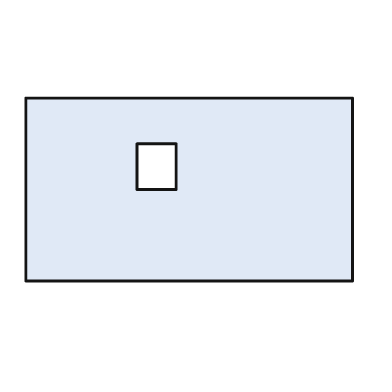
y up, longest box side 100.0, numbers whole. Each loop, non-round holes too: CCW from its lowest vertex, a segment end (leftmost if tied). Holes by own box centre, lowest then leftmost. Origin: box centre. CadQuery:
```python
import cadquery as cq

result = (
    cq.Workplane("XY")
    .moveTo(-50.0, -28.0)
    .lineTo(50.0, -28.0)
    .lineTo(50.0, 28.0)
    .lineTo(-50.0, 28.0)
    .close()
    .moveTo(-16.0, 0.0)
    .lineTo(-4.0, 0.0)
    .lineTo(-4.0, 14.0)
    .lineTo(-16.0, 14.0)
    .close()
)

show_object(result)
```